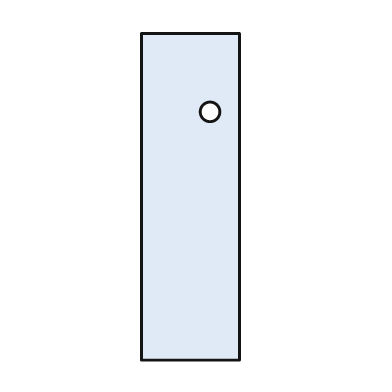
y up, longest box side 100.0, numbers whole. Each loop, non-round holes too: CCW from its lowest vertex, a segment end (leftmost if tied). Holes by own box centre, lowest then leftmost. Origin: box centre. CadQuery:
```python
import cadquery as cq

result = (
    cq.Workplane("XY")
    .moveTo(-15.0, -50.0)
    .lineTo(15.0, -50.0)
    .lineTo(15.0, 50.0)
    .lineTo(-15.0, 50.0)
    .close()
    .moveTo(6.0, 26.0)
    .circle(3.0)
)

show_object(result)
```